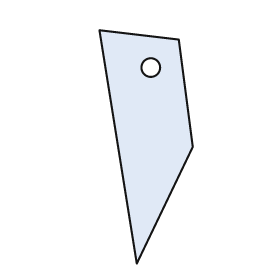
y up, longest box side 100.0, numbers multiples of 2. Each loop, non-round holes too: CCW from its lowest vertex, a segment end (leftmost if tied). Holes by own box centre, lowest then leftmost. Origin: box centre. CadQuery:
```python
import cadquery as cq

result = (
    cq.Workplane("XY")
    .moveTo(-4.0, -50.0)
    .lineTo(20.0, 0.0)
    .lineTo(14.0, 46.0)
    .lineTo(-20.0, 50.0)
    .close()
    .moveTo(2.0, 34.0)
    .circle(4.0)
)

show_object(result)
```